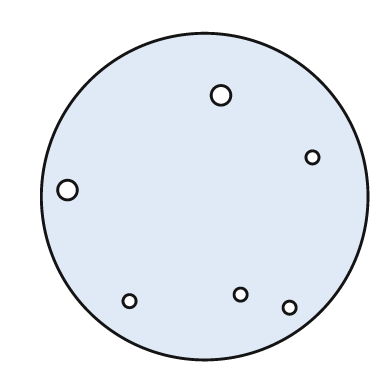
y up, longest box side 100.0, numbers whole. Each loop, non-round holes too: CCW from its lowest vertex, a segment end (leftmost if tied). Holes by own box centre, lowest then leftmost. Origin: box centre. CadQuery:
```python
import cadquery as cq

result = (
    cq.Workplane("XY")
    .moveTo(0.0, 0.0)
    .circle(50.0)
    .moveTo(26.0, -34.0)
    .circle(2.0)
    .moveTo(-23.0, -32.0)
    .circle(2.0)
    .moveTo(11.0, -30.0)
    .circle(2.0)
    .moveTo(-42.0, 2.0)
    .circle(3.0)
    .moveTo(33.0, 12.0)
    .circle(2.0)
    .moveTo(5.0, 31.0)
    .circle(3.0)
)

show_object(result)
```